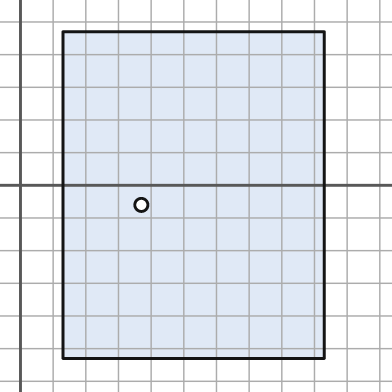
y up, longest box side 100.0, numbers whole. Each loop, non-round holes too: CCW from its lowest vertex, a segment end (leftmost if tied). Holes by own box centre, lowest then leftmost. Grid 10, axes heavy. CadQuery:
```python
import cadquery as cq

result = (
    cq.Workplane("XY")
    .moveTo(13.0, -53.0)
    .lineTo(93.0, -53.0)
    .lineTo(93.0, 47.0)
    .lineTo(13.0, 47.0)
    .close()
    .moveTo(37.0, -6.0)
    .circle(2.0)
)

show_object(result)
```